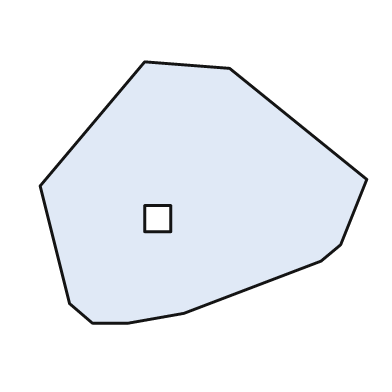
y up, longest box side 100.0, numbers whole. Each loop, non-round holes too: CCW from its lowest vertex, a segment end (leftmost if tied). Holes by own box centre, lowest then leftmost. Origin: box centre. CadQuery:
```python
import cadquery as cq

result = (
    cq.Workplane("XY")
    .moveTo(-34.0, -40.0)
    .lineTo(-23.0, -40.0)
    .lineTo(-6.0, -37.0)
    .lineTo(36.0, -21.0)
    .lineTo(42.0, -16.0)
    .lineTo(50.0, 4.0)
    .lineTo(8.0, 38.0)
    .lineTo(-18.0, 40.0)
    .lineTo(-50.0, 2.0)
    .lineTo(-41.0, -34.0)
    .close()
    .moveTo(-18.0, -12.0)
    .lineTo(-10.0, -12.0)
    .lineTo(-10.0, -4.0)
    .lineTo(-18.0, -4.0)
    .close()
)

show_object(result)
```